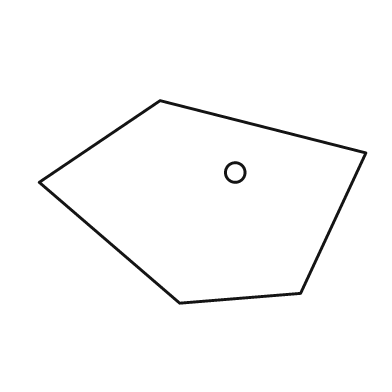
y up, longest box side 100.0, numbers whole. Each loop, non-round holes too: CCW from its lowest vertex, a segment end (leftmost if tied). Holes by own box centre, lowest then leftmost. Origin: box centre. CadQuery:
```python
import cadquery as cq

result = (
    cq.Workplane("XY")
    .moveTo(-7.0, -31.0)
    .lineTo(30.0, -28.0)
    .lineTo(50.0, 15.0)
    .lineTo(-13.0, 31.0)
    .lineTo(-50.0, 6.0)
    .close()
    .moveTo(10.0, 9.0)
    .circle(3.0)
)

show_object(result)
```